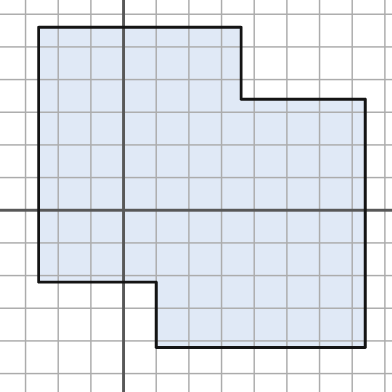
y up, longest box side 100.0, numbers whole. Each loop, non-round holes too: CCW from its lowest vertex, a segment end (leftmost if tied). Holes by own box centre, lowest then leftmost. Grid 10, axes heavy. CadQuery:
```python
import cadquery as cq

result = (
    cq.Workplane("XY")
    .moveTo(10.0, -42.0)
    .lineTo(74.0, -42.0)
    .lineTo(74.0, 34.0)
    .lineTo(36.0, 34.0)
    .lineTo(36.0, 56.0)
    .lineTo(-26.0, 56.0)
    .lineTo(-26.0, -22.0)
    .lineTo(10.0, -22.0)
    .close()
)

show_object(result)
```